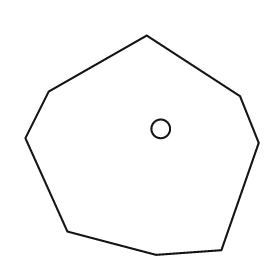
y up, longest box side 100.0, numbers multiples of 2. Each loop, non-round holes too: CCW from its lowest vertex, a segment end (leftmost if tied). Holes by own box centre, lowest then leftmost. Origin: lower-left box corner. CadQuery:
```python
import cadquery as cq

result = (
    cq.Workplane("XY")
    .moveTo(56.0, 0.0)
    .lineTo(84.0, 2.0)
    .lineTo(100.0, 48.0)
    .lineTo(92.0, 68.0)
    .lineTo(52.0, 94.0)
    .lineTo(10.0, 70.0)
    .lineTo(0.0, 50.0)
    .lineTo(18.0, 10.0)
    .close()
    .moveTo(58.0, 54.0)
    .circle(4.0)
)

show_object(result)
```